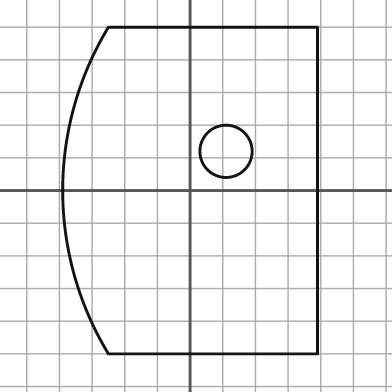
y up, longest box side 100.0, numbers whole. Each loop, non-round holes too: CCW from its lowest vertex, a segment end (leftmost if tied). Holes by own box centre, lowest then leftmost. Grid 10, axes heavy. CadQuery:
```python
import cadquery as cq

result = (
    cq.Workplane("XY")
    .moveTo(-25.0, -50.0)
    .lineTo(39.0, -50.0)
    .lineTo(39.0, 50.0)
    .lineTo(-25.0, 50.0)
    .threePointArc((-39.0, 0.0), (-25.0, -50.0))
    .close()
    .moveTo(11.0, 12.0)
    .circle(8.0)
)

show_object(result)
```